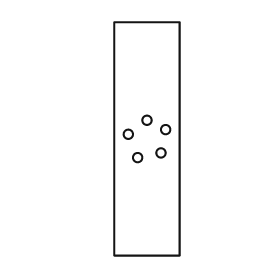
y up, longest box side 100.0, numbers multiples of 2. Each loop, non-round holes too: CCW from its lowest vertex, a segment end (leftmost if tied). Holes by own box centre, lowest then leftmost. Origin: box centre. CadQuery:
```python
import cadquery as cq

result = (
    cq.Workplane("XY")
    .moveTo(-14.0, -50.0)
    .lineTo(14.0, -50.0)
    .lineTo(14.0, 50.0)
    .lineTo(-14.0, 50.0)
    .close()
    .moveTo(-4.0, -8.0)
    .circle(2.0)
    .moveTo(6.0, -6.0)
    .circle(2.0)
    .moveTo(-8.0, 2.0)
    .circle(2.0)
    .moveTo(8.0, 4.0)
    .circle(2.0)
    .moveTo(0.0, 8.0)
    .circle(2.0)
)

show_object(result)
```